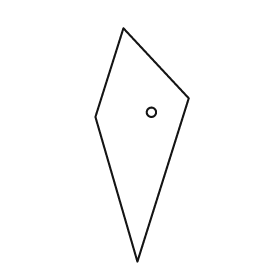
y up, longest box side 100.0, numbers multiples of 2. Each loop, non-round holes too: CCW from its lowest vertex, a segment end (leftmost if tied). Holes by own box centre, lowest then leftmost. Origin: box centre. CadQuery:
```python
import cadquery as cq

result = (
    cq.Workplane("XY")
    .moveTo(-2.0, -50.0)
    .lineTo(20.0, 20.0)
    .lineTo(-8.0, 50.0)
    .lineTo(-20.0, 12.0)
    .close()
    .moveTo(4.0, 14.0)
    .circle(2.0)
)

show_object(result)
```